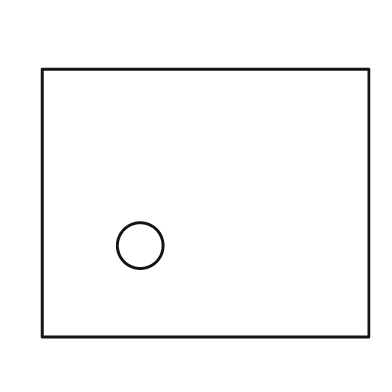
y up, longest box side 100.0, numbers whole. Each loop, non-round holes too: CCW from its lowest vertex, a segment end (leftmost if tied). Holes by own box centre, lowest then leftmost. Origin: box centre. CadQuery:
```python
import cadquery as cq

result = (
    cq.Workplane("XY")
    .moveTo(-50.0, -41.0)
    .lineTo(50.0, -41.0)
    .lineTo(50.0, 41.0)
    .lineTo(-50.0, 41.0)
    .close()
    .moveTo(-20.0, -13.0)
    .circle(7.0)
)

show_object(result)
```